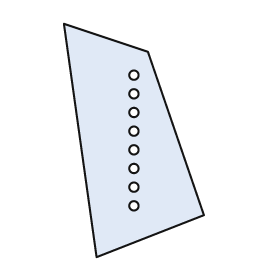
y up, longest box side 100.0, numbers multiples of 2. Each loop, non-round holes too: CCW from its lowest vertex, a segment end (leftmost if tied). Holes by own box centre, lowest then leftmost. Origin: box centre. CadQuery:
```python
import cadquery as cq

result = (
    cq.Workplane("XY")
    .moveTo(-16.0, -50.0)
    .lineTo(30.0, -32.0)
    .lineTo(6.0, 38.0)
    .lineTo(-30.0, 50.0)
    .close()
    .moveTo(0.0, -28.0)
    .circle(2.0)
    .moveTo(0.0, -20.0)
    .circle(2.0)
    .moveTo(0.0, -12.0)
    .circle(2.0)
    .moveTo(0.0, -4.0)
    .circle(2.0)
    .moveTo(0.0, 4.0)
    .circle(2.0)
    .moveTo(0.0, 12.0)
    .circle(2.0)
    .moveTo(0.0, 20.0)
    .circle(2.0)
    .moveTo(0.0, 28.0)
    .circle(2.0)
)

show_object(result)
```